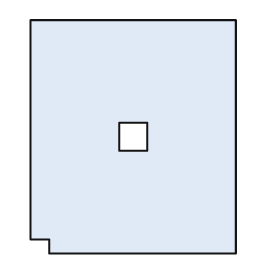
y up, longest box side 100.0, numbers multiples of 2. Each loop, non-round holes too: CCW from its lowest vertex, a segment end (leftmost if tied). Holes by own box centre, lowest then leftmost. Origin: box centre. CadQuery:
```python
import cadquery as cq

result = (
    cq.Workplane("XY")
    .moveTo(-36.0, -50.0)
    .lineTo(44.0, -50.0)
    .lineTo(44.0, 50.0)
    .lineTo(-44.0, 50.0)
    .lineTo(-44.0, -44.0)
    .lineTo(-36.0, -44.0)
    .close()
    .moveTo(-6.0, -6.0)
    .lineTo(6.0, -6.0)
    .lineTo(6.0, 6.0)
    .lineTo(-6.0, 6.0)
    .close()
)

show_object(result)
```